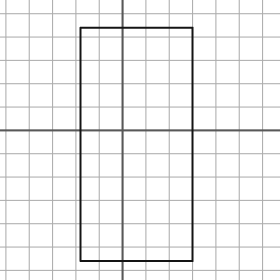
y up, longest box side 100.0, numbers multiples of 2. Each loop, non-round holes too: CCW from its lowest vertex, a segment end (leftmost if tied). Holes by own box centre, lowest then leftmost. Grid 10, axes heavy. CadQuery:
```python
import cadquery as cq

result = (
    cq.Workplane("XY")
    .moveTo(-18.0, -56.0)
    .lineTo(30.0, -56.0)
    .lineTo(30.0, 44.0)
    .lineTo(-18.0, 44.0)
    .close()
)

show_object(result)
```